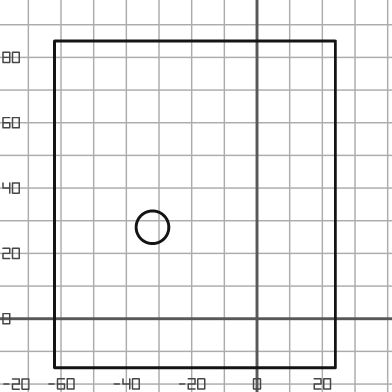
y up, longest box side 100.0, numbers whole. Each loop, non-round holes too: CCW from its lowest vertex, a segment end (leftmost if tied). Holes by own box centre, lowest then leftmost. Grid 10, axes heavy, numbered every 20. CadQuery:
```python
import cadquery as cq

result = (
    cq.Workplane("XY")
    .moveTo(-62.0, -15.0)
    .lineTo(24.0, -15.0)
    .lineTo(24.0, 85.0)
    .lineTo(-62.0, 85.0)
    .close()
    .moveTo(-32.0, 28.0)
    .circle(5.0)
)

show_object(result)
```